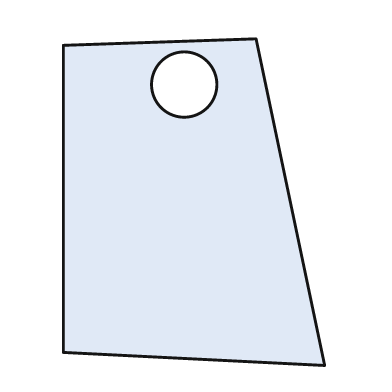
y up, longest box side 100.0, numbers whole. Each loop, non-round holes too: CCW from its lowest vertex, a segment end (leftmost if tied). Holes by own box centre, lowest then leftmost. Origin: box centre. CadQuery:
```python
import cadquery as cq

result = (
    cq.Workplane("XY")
    .moveTo(40.0, -50.0)
    .lineTo(19.0, 50.0)
    .lineTo(-40.0, 48.0)
    .lineTo(-40.0, -46.0)
    .close()
    .moveTo(-3.0, 36.0)
    .circle(10.0)
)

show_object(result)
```